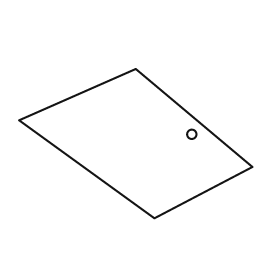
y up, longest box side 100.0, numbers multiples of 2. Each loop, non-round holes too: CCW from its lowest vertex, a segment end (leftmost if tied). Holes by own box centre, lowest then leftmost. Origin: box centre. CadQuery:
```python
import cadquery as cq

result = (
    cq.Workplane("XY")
    .moveTo(8.0, -32.0)
    .lineTo(50.0, -10.0)
    .lineTo(0.0, 32.0)
    .lineTo(-50.0, 10.0)
    .close()
    .moveTo(24.0, 4.0)
    .circle(2.0)
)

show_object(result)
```